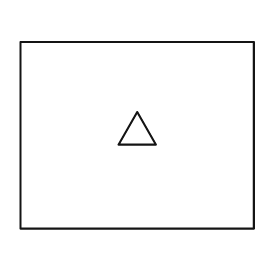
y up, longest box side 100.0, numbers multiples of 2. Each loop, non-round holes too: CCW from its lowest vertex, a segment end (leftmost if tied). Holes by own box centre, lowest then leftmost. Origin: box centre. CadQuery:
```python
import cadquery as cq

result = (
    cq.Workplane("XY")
    .moveTo(-50.0, -40.0)
    .lineTo(50.0, -40.0)
    .lineTo(50.0, 40.0)
    .lineTo(-50.0, 40.0)
    .close()
    .moveTo(-8.0, -4.0)
    .lineTo(8.0, -4.0)
    .lineTo(0.0, 10.0)
    .close()
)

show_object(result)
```